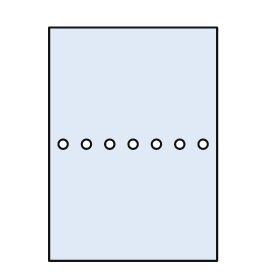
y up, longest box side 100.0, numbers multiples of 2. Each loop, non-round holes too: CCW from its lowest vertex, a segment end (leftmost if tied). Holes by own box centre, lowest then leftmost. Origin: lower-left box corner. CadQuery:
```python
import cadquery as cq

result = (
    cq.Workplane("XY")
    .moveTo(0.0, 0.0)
    .lineTo(72.0, 0.0)
    .lineTo(72.0, 100.0)
    .lineTo(0.0, 100.0)
    .close()
    .moveTo(6.0, 50.0)
    .circle(2.0)
    .moveTo(16.0, 50.0)
    .circle(2.0)
    .moveTo(26.0, 50.0)
    .circle(2.0)
    .moveTo(36.0, 50.0)
    .circle(2.0)
    .moveTo(46.0, 50.0)
    .circle(2.0)
    .moveTo(56.0, 50.0)
    .circle(2.0)
    .moveTo(66.0, 50.0)
    .circle(2.0)
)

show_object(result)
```